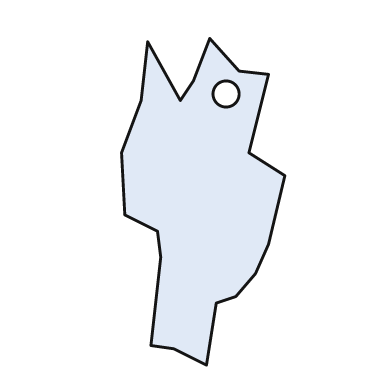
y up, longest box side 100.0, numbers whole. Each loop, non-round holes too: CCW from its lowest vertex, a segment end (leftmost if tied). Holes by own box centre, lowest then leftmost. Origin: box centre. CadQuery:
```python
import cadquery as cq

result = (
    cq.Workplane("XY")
    .moveTo(1.0, -50.0)
    .lineTo(4.0, -31.0)
    .lineTo(10.0, -29.0)
    .lineTo(16.0, -22.0)
    .lineTo(20.0, -13.0)
    .lineTo(25.0, 8.0)
    .lineTo(14.0, 15.0)
    .lineTo(20.0, 39.0)
    .lineTo(11.0, 40.0)
    .lineTo(2.0, 50.0)
    .lineTo(-3.0, 37.0)
    .lineTo(-7.0, 31.0)
    .lineTo(-17.0, 49.0)
    .lineTo(-19.0, 31.0)
    .lineTo(-25.0, 15.0)
    .lineTo(-24.0, -4.0)
    .lineTo(-14.0, -9.0)
    .lineTo(-13.0, -17.0)
    .lineTo(-16.0, -44.0)
    .lineTo(-9.0, -45.0)
    .close()
    .moveTo(7.0, 33.0)
    .circle(4.0)
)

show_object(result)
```